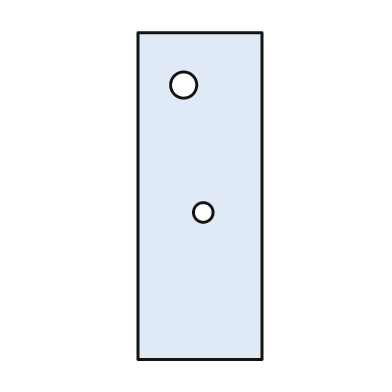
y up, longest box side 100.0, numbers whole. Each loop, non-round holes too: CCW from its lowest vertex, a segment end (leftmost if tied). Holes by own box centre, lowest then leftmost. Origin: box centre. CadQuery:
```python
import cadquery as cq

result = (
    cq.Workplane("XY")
    .moveTo(-19.0, -50.0)
    .lineTo(19.0, -50.0)
    .lineTo(19.0, 50.0)
    .lineTo(-19.0, 50.0)
    .close()
    .moveTo(1.0, -5.0)
    .circle(3.0)
    .moveTo(-5.0, 34.0)
    .circle(4.0)
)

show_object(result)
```